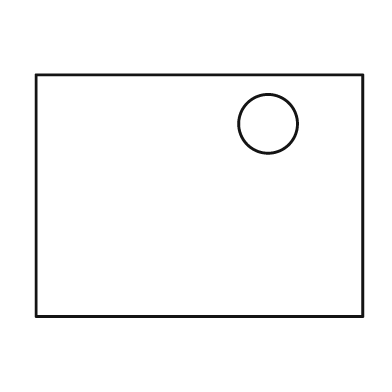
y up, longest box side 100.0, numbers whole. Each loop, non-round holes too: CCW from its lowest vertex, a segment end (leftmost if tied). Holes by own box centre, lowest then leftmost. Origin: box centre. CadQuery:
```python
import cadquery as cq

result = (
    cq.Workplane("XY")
    .moveTo(-50.0, -37.0)
    .lineTo(50.0, -37.0)
    .lineTo(50.0, 37.0)
    .lineTo(-50.0, 37.0)
    .close()
    .moveTo(21.0, 22.0)
    .circle(9.0)
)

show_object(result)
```